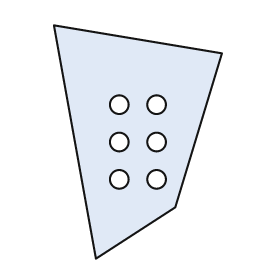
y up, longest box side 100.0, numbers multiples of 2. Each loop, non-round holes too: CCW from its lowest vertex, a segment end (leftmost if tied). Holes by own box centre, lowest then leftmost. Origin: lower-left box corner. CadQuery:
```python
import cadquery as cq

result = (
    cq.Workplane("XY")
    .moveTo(18.0, 0.0)
    .lineTo(52.0, 22.0)
    .lineTo(72.0, 88.0)
    .lineTo(0.0, 100.0)
    .close()
    .moveTo(28.0, 34.0)
    .circle(4.0)
    .moveTo(44.0, 34.0)
    .circle(4.0)
    .moveTo(28.0, 50.0)
    .circle(4.0)
    .moveTo(44.0, 50.0)
    .circle(4.0)
    .moveTo(28.0, 66.0)
    .circle(4.0)
    .moveTo(44.0, 66.0)
    .circle(4.0)
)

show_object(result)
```